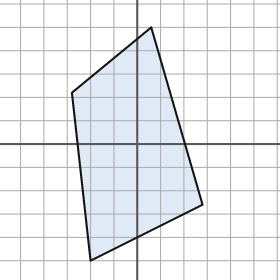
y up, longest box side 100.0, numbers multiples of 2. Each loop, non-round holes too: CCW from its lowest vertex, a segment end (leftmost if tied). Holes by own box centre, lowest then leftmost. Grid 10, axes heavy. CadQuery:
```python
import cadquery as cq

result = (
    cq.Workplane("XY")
    .moveTo(-20.0, -50.0)
    .lineTo(28.0, -26.0)
    .lineTo(6.0, 50.0)
    .lineTo(-28.0, 22.0)
    .close()
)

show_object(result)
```